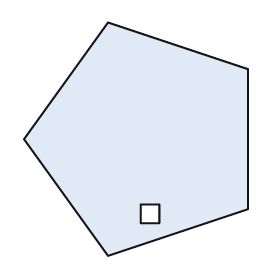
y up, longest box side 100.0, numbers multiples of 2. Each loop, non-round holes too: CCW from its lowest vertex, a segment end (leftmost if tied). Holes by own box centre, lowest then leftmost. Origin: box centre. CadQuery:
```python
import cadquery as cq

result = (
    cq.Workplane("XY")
    .moveTo(-12.0, -50.0)
    .lineTo(48.0, -30.0)
    .lineTo(48.0, 30.0)
    .lineTo(-12.0, 50.0)
    .lineTo(-48.0, 0.0)
    .close()
    .moveTo(2.0, -36.0)
    .lineTo(10.0, -36.0)
    .lineTo(10.0, -28.0)
    .lineTo(2.0, -28.0)
    .close()
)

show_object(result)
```